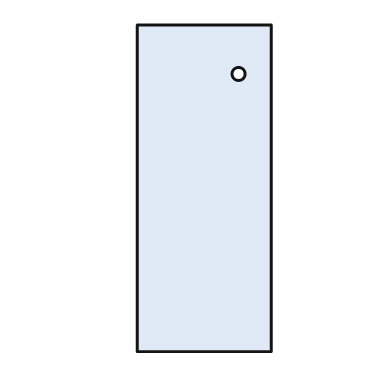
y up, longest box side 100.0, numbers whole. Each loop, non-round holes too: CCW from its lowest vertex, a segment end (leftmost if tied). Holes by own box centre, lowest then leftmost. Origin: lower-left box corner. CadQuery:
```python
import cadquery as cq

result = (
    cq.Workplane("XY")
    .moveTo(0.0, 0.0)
    .lineTo(41.0, 0.0)
    .lineTo(41.0, 100.0)
    .lineTo(0.0, 100.0)
    .close()
    .moveTo(31.0, 85.0)
    .circle(2.0)
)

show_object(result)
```